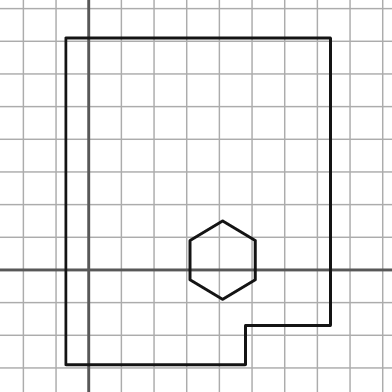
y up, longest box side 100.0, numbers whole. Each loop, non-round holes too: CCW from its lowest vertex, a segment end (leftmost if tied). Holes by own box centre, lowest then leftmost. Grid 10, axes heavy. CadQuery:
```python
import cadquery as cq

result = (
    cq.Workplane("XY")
    .moveTo(-7.0, -29.0)
    .lineTo(48.0, -29.0)
    .lineTo(48.0, -17.0)
    .lineTo(74.0, -17.0)
    .lineTo(74.0, 71.0)
    .lineTo(-7.0, 71.0)
    .close()
    .moveTo(41.0, -9.0)
    .lineTo(51.0, -3.0)
    .lineTo(51.0, 9.0)
    .lineTo(41.0, 15.0)
    .lineTo(31.0, 9.0)
    .lineTo(31.0, -3.0)
    .close()
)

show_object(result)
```